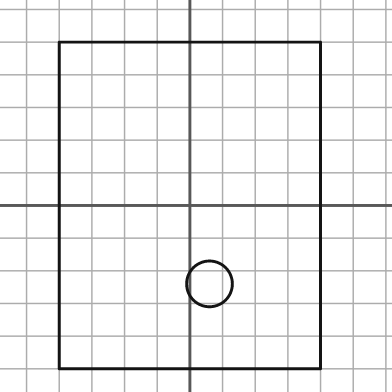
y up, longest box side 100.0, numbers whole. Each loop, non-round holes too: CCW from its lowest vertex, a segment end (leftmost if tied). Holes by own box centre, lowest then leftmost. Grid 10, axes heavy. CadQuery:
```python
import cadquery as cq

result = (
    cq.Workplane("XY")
    .moveTo(-40.0, -50.0)
    .lineTo(40.0, -50.0)
    .lineTo(40.0, 50.0)
    .lineTo(-40.0, 50.0)
    .close()
    .moveTo(6.0, -24.0)
    .circle(7.0)
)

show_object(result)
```